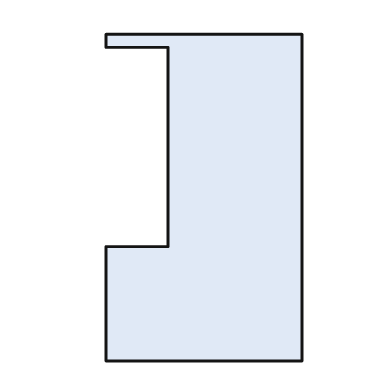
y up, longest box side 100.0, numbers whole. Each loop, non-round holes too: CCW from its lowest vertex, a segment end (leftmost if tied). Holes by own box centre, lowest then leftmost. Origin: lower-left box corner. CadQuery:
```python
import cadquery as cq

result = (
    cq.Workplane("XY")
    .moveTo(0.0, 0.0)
    .lineTo(60.0, 0.0)
    .lineTo(60.0, 100.0)
    .lineTo(0.0, 100.0)
    .lineTo(0.0, 96.0)
    .lineTo(19.0, 96.0)
    .lineTo(19.0, 35.0)
    .lineTo(0.0, 35.0)
    .close()
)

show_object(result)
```